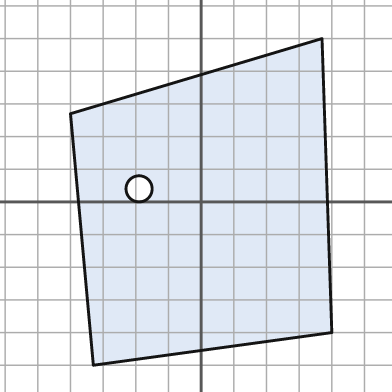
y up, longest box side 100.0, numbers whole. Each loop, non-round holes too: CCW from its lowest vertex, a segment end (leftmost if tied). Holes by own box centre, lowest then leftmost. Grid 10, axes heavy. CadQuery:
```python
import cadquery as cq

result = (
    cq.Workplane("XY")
    .moveTo(-33.0, -50.0)
    .lineTo(40.0, -40.0)
    .lineTo(37.0, 50.0)
    .lineTo(-40.0, 27.0)
    .close()
    .moveTo(-19.0, 4.0)
    .circle(4.0)
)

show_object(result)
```